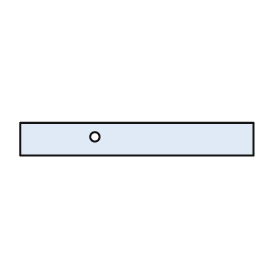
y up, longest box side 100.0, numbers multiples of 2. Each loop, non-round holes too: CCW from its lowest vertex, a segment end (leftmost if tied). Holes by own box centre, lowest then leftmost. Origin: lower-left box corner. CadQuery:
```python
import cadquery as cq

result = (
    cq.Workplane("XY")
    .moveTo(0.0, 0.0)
    .lineTo(100.0, 0.0)
    .lineTo(100.0, 14.0)
    .lineTo(0.0, 14.0)
    .close()
    .moveTo(32.0, 8.0)
    .circle(2.0)
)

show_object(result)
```